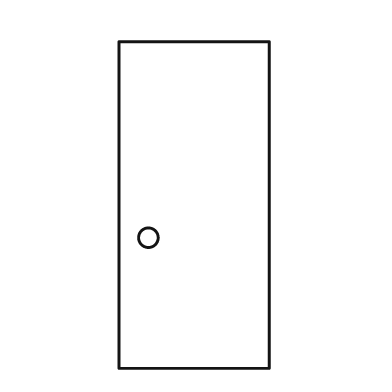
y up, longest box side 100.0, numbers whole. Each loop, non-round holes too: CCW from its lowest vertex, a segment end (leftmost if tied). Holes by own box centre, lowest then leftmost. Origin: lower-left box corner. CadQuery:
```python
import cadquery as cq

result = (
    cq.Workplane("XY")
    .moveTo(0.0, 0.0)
    .lineTo(46.0, 0.0)
    .lineTo(46.0, 100.0)
    .lineTo(0.0, 100.0)
    .close()
    .moveTo(9.0, 40.0)
    .circle(3.0)
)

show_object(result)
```